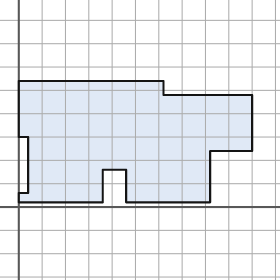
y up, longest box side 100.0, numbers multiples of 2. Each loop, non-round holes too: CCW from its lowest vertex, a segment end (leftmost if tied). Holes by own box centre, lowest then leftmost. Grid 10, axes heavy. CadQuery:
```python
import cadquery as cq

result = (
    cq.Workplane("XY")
    .moveTo(0.0, 2.0)
    .lineTo(36.0, 2.0)
    .lineTo(36.0, 16.0)
    .lineTo(46.0, 16.0)
    .lineTo(46.0, 2.0)
    .lineTo(82.0, 2.0)
    .lineTo(82.0, 24.0)
    .lineTo(100.0, 24.0)
    .lineTo(100.0, 48.0)
    .lineTo(62.0, 48.0)
    .lineTo(62.0, 54.0)
    .lineTo(0.0, 54.0)
    .lineTo(0.0, 30.0)
    .lineTo(4.0, 30.0)
    .lineTo(4.0, 6.0)
    .lineTo(0.0, 6.0)
    .close()
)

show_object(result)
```